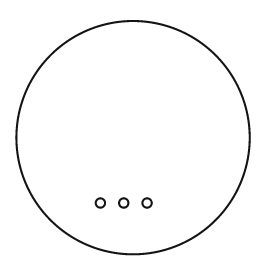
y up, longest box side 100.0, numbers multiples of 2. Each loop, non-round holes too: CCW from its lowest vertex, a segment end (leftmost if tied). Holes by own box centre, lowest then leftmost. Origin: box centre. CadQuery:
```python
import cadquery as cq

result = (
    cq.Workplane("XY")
    .moveTo(0.0, 0.0)
    .circle(50.0)
    .moveTo(-14.0, -28.0)
    .circle(2.0)
    .moveTo(-4.0, -28.0)
    .circle(2.0)
    .moveTo(6.0, -28.0)
    .circle(2.0)
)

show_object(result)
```